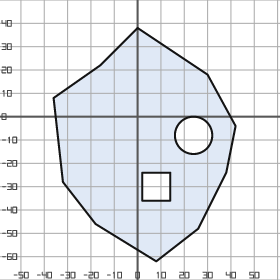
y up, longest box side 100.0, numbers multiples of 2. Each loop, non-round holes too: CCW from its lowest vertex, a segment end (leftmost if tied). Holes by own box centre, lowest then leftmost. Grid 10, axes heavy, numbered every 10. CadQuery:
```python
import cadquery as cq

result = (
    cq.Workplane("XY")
    .moveTo(8.0, -62.0)
    .lineTo(26.0, -48.0)
    .lineTo(38.0, -24.0)
    .lineTo(42.0, -4.0)
    .lineTo(30.0, 18.0)
    .lineTo(0.0, 38.0)
    .lineTo(-16.0, 22.0)
    .lineTo(-36.0, 8.0)
    .lineTo(-32.0, -28.0)
    .lineTo(-18.0, -46.0)
    .close()
    .moveTo(2.0, -36.0)
    .lineTo(14.0, -36.0)
    .lineTo(14.0, -24.0)
    .lineTo(2.0, -24.0)
    .close()
    .moveTo(24.0, -8.0)
    .circle(8.0)
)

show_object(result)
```